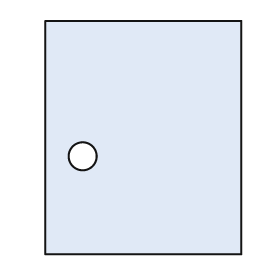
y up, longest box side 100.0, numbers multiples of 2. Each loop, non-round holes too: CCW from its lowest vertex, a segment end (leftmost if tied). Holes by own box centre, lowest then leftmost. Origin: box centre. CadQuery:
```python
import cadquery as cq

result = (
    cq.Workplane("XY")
    .moveTo(-42.0, -50.0)
    .lineTo(42.0, -50.0)
    .lineTo(42.0, 50.0)
    .lineTo(-42.0, 50.0)
    .close()
    .moveTo(-26.0, -8.0)
    .circle(6.0)
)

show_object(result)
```